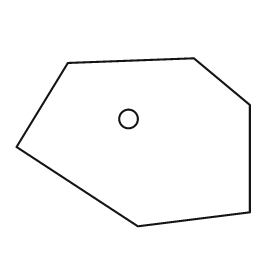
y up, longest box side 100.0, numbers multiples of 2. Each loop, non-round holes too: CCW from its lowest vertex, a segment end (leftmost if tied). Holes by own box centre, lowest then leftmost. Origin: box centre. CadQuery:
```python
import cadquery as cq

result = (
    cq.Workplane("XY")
    .moveTo(2.0, -36.0)
    .lineTo(50.0, -30.0)
    .lineTo(50.0, 16.0)
    .lineTo(26.0, 36.0)
    .lineTo(-28.0, 34.0)
    .lineTo(-50.0, -2.0)
    .close()
    .moveTo(-2.0, 10.0)
    .circle(4.0)
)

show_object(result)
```